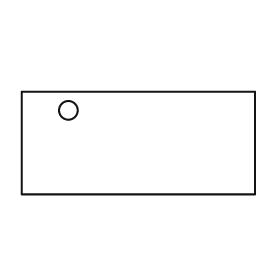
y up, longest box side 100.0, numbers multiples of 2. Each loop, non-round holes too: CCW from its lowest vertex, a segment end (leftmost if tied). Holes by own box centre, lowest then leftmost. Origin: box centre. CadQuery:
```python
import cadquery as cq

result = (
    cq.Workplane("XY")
    .moveTo(-50.0, -22.0)
    .lineTo(50.0, -22.0)
    .lineTo(50.0, 22.0)
    .lineTo(-50.0, 22.0)
    .close()
    .moveTo(-30.0, 14.0)
    .circle(4.0)
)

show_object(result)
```